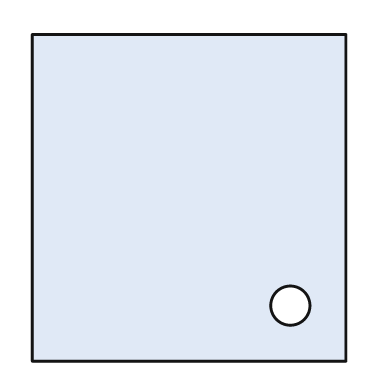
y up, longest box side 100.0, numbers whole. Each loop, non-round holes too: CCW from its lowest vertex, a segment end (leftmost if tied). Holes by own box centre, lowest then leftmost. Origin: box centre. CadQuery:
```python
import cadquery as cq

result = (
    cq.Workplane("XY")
    .moveTo(-48.0, -50.0)
    .lineTo(48.0, -50.0)
    .lineTo(48.0, 50.0)
    .lineTo(-48.0, 50.0)
    .close()
    .moveTo(31.0, -33.0)
    .circle(6.0)
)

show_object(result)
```